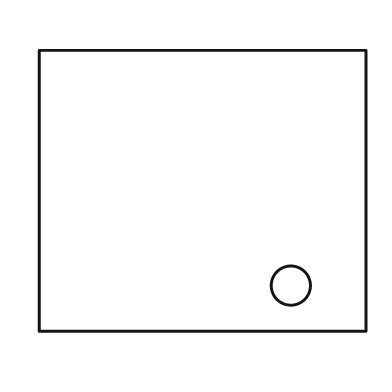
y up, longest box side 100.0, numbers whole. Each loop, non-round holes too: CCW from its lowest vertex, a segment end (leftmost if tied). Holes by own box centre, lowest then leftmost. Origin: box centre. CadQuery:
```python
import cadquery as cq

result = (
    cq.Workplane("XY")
    .moveTo(-50.0, -43.0)
    .lineTo(50.0, -43.0)
    .lineTo(50.0, 43.0)
    .lineTo(-50.0, 43.0)
    .close()
    .moveTo(27.0, -29.0)
    .circle(6.0)
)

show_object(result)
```